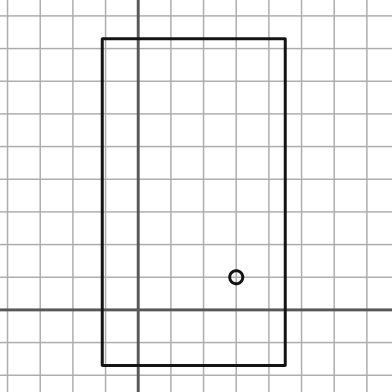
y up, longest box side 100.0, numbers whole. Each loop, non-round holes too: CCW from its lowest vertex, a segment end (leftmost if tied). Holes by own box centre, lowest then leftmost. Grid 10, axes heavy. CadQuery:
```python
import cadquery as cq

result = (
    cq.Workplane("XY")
    .moveTo(-11.0, -17.0)
    .lineTo(45.0, -17.0)
    .lineTo(45.0, 83.0)
    .lineTo(-11.0, 83.0)
    .close()
    .moveTo(30.0, 10.0)
    .circle(2.0)
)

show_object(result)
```